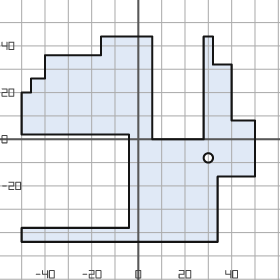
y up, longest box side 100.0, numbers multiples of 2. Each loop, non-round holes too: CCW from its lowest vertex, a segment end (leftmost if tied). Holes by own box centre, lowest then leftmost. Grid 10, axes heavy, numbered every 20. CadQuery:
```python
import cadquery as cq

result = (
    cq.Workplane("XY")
    .moveTo(-50.0, -44.0)
    .lineTo(34.0, -44.0)
    .lineTo(34.0, -16.0)
    .lineTo(50.0, -16.0)
    .lineTo(50.0, 8.0)
    .lineTo(40.0, 8.0)
    .lineTo(40.0, 32.0)
    .lineTo(32.0, 32.0)
    .lineTo(32.0, 44.0)
    .lineTo(28.0, 44.0)
    .lineTo(28.0, 0.0)
    .lineTo(6.0, 0.0)
    .lineTo(6.0, 44.0)
    .lineTo(-16.0, 44.0)
    .lineTo(-16.0, 36.0)
    .lineTo(-40.0, 36.0)
    .lineTo(-40.0, 26.0)
    .lineTo(-46.0, 26.0)
    .lineTo(-46.0, 20.0)
    .lineTo(-50.0, 20.0)
    .lineTo(-50.0, 2.0)
    .lineTo(-4.0, 2.0)
    .lineTo(-4.0, -38.0)
    .lineTo(-50.0, -38.0)
    .close()
    .moveTo(30.0, -8.0)
    .circle(2.0)
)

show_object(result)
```